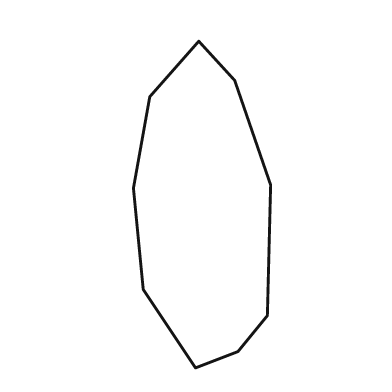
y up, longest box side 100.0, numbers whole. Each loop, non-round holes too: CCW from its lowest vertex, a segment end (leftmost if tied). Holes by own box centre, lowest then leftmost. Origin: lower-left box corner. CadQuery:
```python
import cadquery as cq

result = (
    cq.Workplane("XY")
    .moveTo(19.0, 0.0)
    .lineTo(32.0, 5.0)
    .lineTo(41.0, 16.0)
    .lineTo(42.0, 56.0)
    .lineTo(31.0, 88.0)
    .lineTo(20.0, 100.0)
    .lineTo(5.0, 83.0)
    .lineTo(0.0, 55.0)
    .lineTo(3.0, 24.0)
    .close()
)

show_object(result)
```